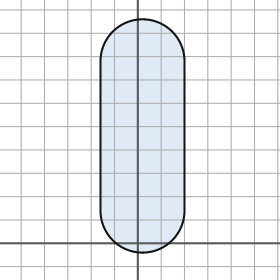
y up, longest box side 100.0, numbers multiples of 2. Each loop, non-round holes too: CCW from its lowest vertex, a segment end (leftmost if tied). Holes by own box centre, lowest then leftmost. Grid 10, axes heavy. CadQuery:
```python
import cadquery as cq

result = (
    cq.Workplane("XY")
    .moveTo(-16.0, 14.0)
    .threePointArc((2.0, -4.0), (20.0, 14.0))
    .lineTo(20.0, 78.0)
    .threePointArc((2.0, 96.0), (-16.0, 78.0))
    .close()
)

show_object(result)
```